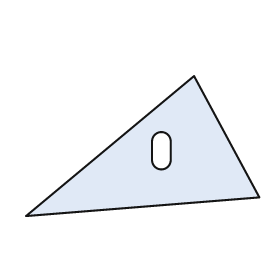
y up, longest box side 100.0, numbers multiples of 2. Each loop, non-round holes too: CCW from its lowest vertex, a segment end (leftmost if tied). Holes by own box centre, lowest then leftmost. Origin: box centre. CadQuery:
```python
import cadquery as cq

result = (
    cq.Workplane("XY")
    .moveTo(-50.0, -30.0)
    .lineTo(50.0, -22.0)
    .lineTo(22.0, 30.0)
    .close()
    .moveTo(4.0, -6.0)
    .threePointArc((8.0, -10.0), (12.0, -6.0))
    .lineTo(12.0, 2.0)
    .threePointArc((8.0, 6.0), (4.0, 2.0))
    .close()
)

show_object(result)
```